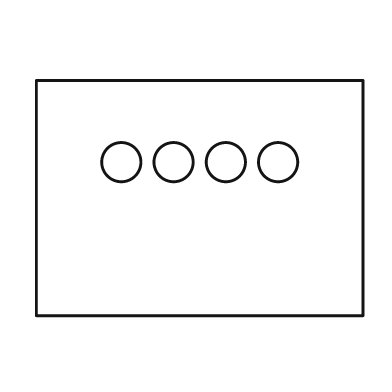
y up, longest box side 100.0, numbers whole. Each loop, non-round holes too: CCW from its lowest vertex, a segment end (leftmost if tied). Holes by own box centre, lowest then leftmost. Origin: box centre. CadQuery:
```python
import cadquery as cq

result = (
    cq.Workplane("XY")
    .moveTo(-50.0, -36.0)
    .lineTo(50.0, -36.0)
    .lineTo(50.0, 36.0)
    .lineTo(-50.0, 36.0)
    .close()
    .moveTo(-24.0, 11.0)
    .circle(6.0)
    .moveTo(-8.0, 11.0)
    .circle(6.0)
    .moveTo(8.0, 11.0)
    .circle(6.0)
    .moveTo(24.0, 11.0)
    .circle(6.0)
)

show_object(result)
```